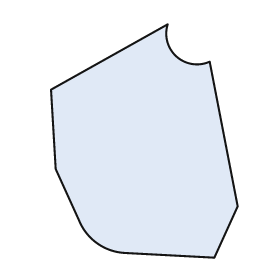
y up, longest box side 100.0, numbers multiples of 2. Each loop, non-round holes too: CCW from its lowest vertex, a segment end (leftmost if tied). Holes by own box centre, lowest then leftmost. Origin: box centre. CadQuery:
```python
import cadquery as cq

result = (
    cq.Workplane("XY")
    .moveTo(30.0, -50.0)
    .lineTo(40.0, -28.0)
    .lineTo(28.0, 34.0)
    .threePointArc((14.0, 36.0), (10.0, 50.0))
    .lineTo(-40.0, 22.0)
    .lineTo(-38.0, -12.0)
    .lineTo(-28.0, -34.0)
    .threePointArc((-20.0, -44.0), (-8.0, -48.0))
    .close()
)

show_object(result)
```